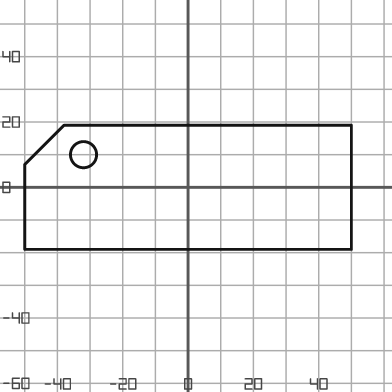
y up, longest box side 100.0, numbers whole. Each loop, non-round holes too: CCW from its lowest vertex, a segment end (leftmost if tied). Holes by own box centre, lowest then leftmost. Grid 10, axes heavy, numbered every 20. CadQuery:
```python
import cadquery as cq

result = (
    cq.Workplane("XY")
    .moveTo(-50.0, -19.0)
    .lineTo(50.0, -19.0)
    .lineTo(50.0, 19.0)
    .lineTo(-38.0, 19.0)
    .lineTo(-50.0, 7.0)
    .close()
    .moveTo(-32.0, 10.0)
    .circle(4.0)
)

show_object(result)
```